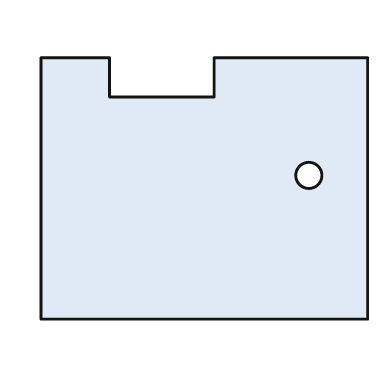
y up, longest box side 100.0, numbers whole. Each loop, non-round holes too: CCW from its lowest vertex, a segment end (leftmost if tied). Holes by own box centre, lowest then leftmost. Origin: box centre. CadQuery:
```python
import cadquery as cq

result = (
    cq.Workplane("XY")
    .moveTo(-50.0, -40.0)
    .lineTo(50.0, -40.0)
    .lineTo(50.0, 40.0)
    .lineTo(3.0, 40.0)
    .lineTo(3.0, 28.0)
    .lineTo(-29.0, 28.0)
    .lineTo(-29.0, 40.0)
    .lineTo(-50.0, 40.0)
    .close()
    .moveTo(32.0, 4.0)
    .circle(4.0)
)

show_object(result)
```